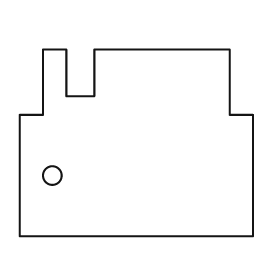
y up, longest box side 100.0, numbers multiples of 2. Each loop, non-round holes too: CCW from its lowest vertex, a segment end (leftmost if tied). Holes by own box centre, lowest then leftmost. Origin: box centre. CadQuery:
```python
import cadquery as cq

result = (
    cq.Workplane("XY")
    .moveTo(-50.0, -40.0)
    .lineTo(50.0, -40.0)
    .lineTo(50.0, 12.0)
    .lineTo(40.0, 12.0)
    .lineTo(40.0, 40.0)
    .lineTo(-18.0, 40.0)
    .lineTo(-18.0, 20.0)
    .lineTo(-30.0, 20.0)
    .lineTo(-30.0, 40.0)
    .lineTo(-40.0, 40.0)
    .lineTo(-40.0, 12.0)
    .lineTo(-50.0, 12.0)
    .close()
    .moveTo(-36.0, -14.0)
    .circle(4.0)
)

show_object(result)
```